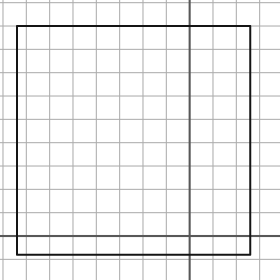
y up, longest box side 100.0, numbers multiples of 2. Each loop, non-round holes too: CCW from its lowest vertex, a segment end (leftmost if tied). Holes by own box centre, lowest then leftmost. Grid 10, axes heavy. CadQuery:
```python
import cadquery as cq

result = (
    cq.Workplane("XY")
    .moveTo(-74.0, -8.0)
    .lineTo(26.0, -8.0)
    .lineTo(26.0, 90.0)
    .lineTo(-74.0, 90.0)
    .close()
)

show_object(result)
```